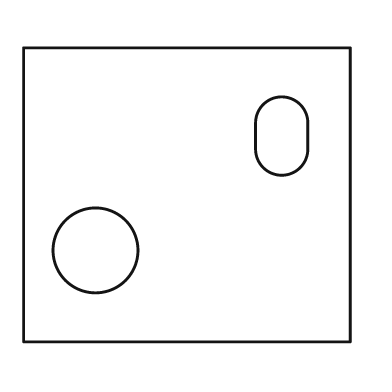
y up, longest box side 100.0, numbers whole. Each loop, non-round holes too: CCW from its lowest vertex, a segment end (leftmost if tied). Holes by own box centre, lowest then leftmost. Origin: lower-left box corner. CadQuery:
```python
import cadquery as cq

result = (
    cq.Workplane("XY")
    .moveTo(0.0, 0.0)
    .lineTo(100.0, 0.0)
    .lineTo(100.0, 90.0)
    .lineTo(0.0, 90.0)
    .close()
    .moveTo(22.0, 28.0)
    .circle(13.0)
    .moveTo(71.0, 59.0)
    .threePointArc((79.0, 51.0), (87.0, 59.0))
    .lineTo(87.0, 67.0)
    .threePointArc((79.0, 75.0), (71.0, 67.0))
    .close()
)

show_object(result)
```